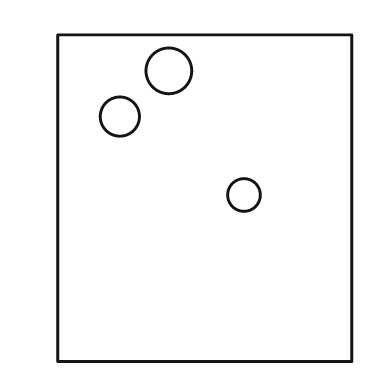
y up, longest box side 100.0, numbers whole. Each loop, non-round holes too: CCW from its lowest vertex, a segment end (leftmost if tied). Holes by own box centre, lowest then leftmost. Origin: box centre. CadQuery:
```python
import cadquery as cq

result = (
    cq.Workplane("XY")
    .moveTo(-45.0, -50.0)
    .lineTo(45.0, -50.0)
    .lineTo(45.0, 50.0)
    .lineTo(-45.0, 50.0)
    .close()
    .moveTo(12.0, 1.0)
    .circle(5.0)
    .moveTo(-26.0, 25.0)
    .circle(6.0)
    .moveTo(-11.0, 39.0)
    .circle(7.0)
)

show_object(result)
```